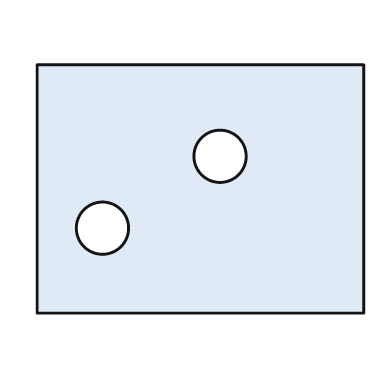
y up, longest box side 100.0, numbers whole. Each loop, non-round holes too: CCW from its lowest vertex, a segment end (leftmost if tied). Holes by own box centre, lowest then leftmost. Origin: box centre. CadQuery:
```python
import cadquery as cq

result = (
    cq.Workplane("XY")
    .moveTo(-50.0, -38.0)
    .lineTo(50.0, -38.0)
    .lineTo(50.0, 38.0)
    .lineTo(-50.0, 38.0)
    .close()
    .moveTo(-30.0, -12.0)
    .circle(8.0)
    .moveTo(6.0, 10.0)
    .circle(8.0)
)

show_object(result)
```